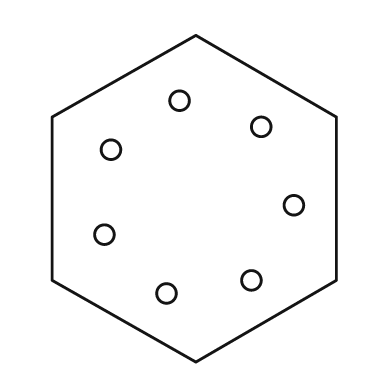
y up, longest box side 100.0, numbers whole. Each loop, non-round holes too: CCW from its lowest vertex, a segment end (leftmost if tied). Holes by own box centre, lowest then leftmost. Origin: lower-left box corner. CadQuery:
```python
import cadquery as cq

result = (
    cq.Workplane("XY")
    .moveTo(44.0, 0.0)
    .lineTo(87.0, 25.0)
    .lineTo(87.0, 75.0)
    .lineTo(44.0, 100.0)
    .lineTo(0.0, 75.0)
    .lineTo(0.0, 25.0)
    .close()
    .moveTo(35.0, 21.0)
    .circle(3.0)
    .moveTo(61.0, 25.0)
    .circle(3.0)
    .moveTo(16.0, 39.0)
    .circle(3.0)
    .moveTo(74.0, 48.0)
    .circle(3.0)
    .moveTo(18.0, 65.0)
    .circle(3.0)
    .moveTo(64.0, 72.0)
    .circle(3.0)
    .moveTo(39.0, 80.0)
    .circle(3.0)
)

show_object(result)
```